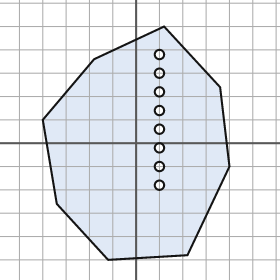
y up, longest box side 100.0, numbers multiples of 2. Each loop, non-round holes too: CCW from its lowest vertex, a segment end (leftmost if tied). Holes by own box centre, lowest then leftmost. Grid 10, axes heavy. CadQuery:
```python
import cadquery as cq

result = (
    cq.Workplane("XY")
    .moveTo(-12.0, -50.0)
    .lineTo(22.0, -48.0)
    .lineTo(40.0, -10.0)
    .lineTo(36.0, 24.0)
    .lineTo(12.0, 50.0)
    .lineTo(-18.0, 36.0)
    .lineTo(-40.0, 10.0)
    .lineTo(-34.0, -26.0)
    .close()
    .moveTo(10.0, -18.0)
    .circle(2.0)
    .moveTo(10.0, -10.0)
    .circle(2.0)
    .moveTo(10.0, -2.0)
    .circle(2.0)
    .moveTo(10.0, 6.0)
    .circle(2.0)
    .moveTo(10.0, 14.0)
    .circle(2.0)
    .moveTo(10.0, 22.0)
    .circle(2.0)
    .moveTo(10.0, 30.0)
    .circle(2.0)
    .moveTo(10.0, 38.0)
    .circle(2.0)
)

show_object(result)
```